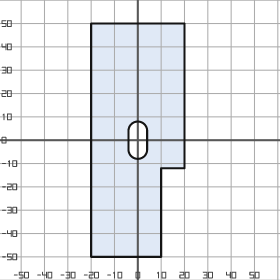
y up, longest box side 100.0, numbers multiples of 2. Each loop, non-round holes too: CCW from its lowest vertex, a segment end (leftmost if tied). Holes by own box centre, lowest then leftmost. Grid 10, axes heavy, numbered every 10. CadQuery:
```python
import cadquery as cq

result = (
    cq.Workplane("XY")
    .moveTo(-20.0, -50.0)
    .lineTo(10.0, -50.0)
    .lineTo(10.0, -12.0)
    .lineTo(20.0, -12.0)
    .lineTo(20.0, 50.0)
    .lineTo(-20.0, 50.0)
    .close()
    .moveTo(-4.0, -4.0)
    .threePointArc((0.0, -8.0), (4.0, -4.0))
    .lineTo(4.0, 4.0)
    .threePointArc((0.0, 8.0), (-4.0, 4.0))
    .close()
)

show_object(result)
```